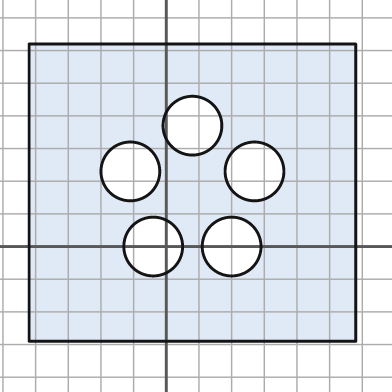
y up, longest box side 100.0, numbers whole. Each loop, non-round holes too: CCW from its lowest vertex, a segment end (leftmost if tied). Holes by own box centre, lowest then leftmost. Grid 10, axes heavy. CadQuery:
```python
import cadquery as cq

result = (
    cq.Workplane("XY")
    .moveTo(-42.0, -29.0)
    .lineTo(58.0, -29.0)
    .lineTo(58.0, 62.0)
    .lineTo(-42.0, 62.0)
    .close()
    .moveTo(-4.0, 0.0)
    .circle(9.0)
    .moveTo(20.0, 0.0)
    .circle(9.0)
    .moveTo(-11.0, 23.0)
    .circle(9.0)
    .moveTo(27.0, 23.0)
    .circle(9.0)
    .moveTo(8.0, 37.0)
    .circle(9.0)
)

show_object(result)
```